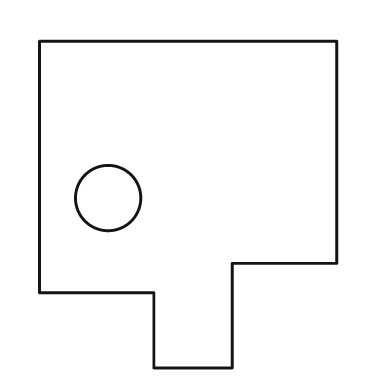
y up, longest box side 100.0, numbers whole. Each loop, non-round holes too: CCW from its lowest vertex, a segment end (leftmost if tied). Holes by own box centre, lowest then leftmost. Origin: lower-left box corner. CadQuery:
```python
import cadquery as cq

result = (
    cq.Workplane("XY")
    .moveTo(35.0, 0.0)
    .lineTo(59.0, 0.0)
    .lineTo(59.0, 32.0)
    .lineTo(91.0, 32.0)
    .lineTo(91.0, 100.0)
    .lineTo(0.0, 100.0)
    .lineTo(0.0, 23.0)
    .lineTo(35.0, 23.0)
    .close()
    .moveTo(21.0, 52.0)
    .circle(10.0)
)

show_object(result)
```